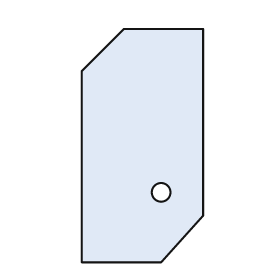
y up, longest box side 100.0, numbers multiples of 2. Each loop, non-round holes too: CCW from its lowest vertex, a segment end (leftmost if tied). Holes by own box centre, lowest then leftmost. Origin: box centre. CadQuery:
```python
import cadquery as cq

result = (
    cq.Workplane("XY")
    .moveTo(-26.0, -50.0)
    .lineTo(8.0, -50.0)
    .lineTo(26.0, -30.0)
    .lineTo(26.0, 50.0)
    .lineTo(-8.0, 50.0)
    .lineTo(-26.0, 32.0)
    .close()
    .moveTo(8.0, -20.0)
    .circle(4.0)
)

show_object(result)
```